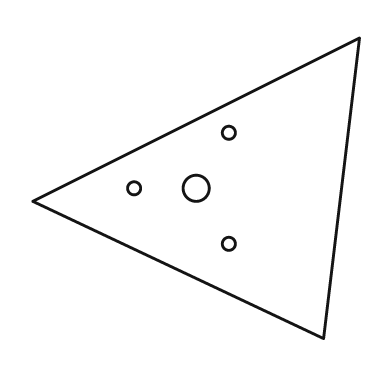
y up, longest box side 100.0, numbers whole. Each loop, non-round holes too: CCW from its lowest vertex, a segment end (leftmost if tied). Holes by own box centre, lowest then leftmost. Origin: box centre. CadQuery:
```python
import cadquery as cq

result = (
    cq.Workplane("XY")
    .moveTo(39.0, -46.0)
    .lineTo(50.0, 46.0)
    .lineTo(-50.0, -4.0)
    .close()
    .moveTo(10.0, -17.0)
    .circle(2.0)
    .moveTo(-19.0, 0.0)
    .circle(2.0)
    .moveTo(0.0, 0.0)
    .circle(4.0)
    .moveTo(10.0, 17.0)
    .circle(2.0)
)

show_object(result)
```